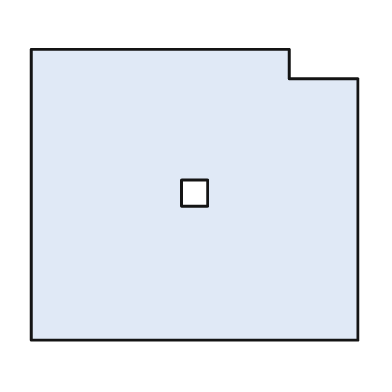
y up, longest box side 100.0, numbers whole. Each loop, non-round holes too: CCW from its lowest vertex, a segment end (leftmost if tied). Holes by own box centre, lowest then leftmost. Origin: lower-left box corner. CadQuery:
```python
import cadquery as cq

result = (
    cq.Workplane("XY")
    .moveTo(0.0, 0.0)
    .lineTo(100.0, 0.0)
    .lineTo(100.0, 80.0)
    .lineTo(79.0, 80.0)
    .lineTo(79.0, 89.0)
    .lineTo(0.0, 89.0)
    .close()
    .moveTo(46.0, 41.0)
    .lineTo(54.0, 41.0)
    .lineTo(54.0, 49.0)
    .lineTo(46.0, 49.0)
    .close()
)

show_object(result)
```